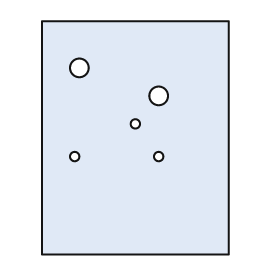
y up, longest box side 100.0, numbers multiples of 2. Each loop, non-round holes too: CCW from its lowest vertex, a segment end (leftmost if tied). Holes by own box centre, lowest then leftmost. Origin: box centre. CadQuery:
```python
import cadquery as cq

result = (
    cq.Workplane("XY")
    .moveTo(-40.0, -50.0)
    .lineTo(40.0, -50.0)
    .lineTo(40.0, 50.0)
    .lineTo(-40.0, 50.0)
    .close()
    .moveTo(-26.0, -8.0)
    .circle(2.0)
    .moveTo(10.0, -8.0)
    .circle(2.0)
    .moveTo(0.0, 6.0)
    .circle(2.0)
    .moveTo(10.0, 18.0)
    .circle(4.0)
    .moveTo(-24.0, 30.0)
    .circle(4.0)
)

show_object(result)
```